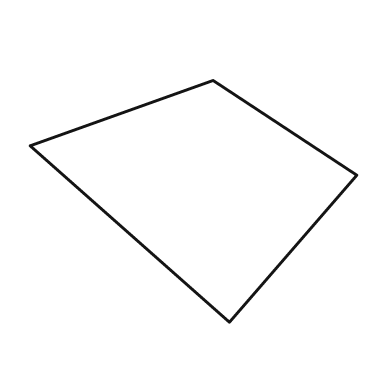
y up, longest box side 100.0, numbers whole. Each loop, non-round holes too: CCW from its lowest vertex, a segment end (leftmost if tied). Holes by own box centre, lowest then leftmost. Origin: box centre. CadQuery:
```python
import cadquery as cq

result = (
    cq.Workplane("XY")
    .moveTo(11.0, -37.0)
    .lineTo(50.0, 8.0)
    .lineTo(6.0, 37.0)
    .lineTo(-50.0, 17.0)
    .close()
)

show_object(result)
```